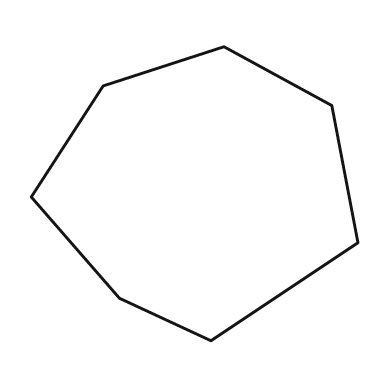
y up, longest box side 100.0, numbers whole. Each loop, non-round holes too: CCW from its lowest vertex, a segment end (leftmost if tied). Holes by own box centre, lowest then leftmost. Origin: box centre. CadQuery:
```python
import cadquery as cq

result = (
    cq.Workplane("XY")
    .moveTo(5.0, -45.0)
    .lineTo(50.0, -15.0)
    .lineTo(42.0, 27.0)
    .lineTo(9.0, 45.0)
    .lineTo(-28.0, 33.0)
    .lineTo(-50.0, -1.0)
    .lineTo(-23.0, -32.0)
    .close()
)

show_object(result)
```